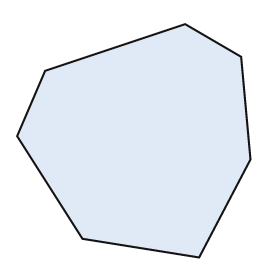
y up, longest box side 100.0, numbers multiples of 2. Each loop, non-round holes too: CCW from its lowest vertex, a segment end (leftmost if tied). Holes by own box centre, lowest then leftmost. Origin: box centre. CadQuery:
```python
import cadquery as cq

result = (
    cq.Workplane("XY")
    .moveTo(28.0, -50.0)
    .lineTo(50.0, -8.0)
    .lineTo(46.0, 36.0)
    .lineTo(22.0, 50.0)
    .lineTo(-38.0, 30.0)
    .lineTo(-50.0, 2.0)
    .lineTo(-22.0, -42.0)
    .close()
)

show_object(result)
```